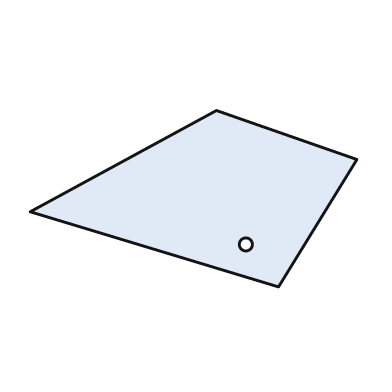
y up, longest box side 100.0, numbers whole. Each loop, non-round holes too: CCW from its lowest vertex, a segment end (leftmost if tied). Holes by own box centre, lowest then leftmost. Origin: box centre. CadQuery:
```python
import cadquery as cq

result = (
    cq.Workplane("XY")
    .moveTo(26.0, -27.0)
    .lineTo(50.0, 12.0)
    .lineTo(7.0, 27.0)
    .lineTo(-50.0, -4.0)
    .close()
    .moveTo(16.0, -14.0)
    .circle(2.0)
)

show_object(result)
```